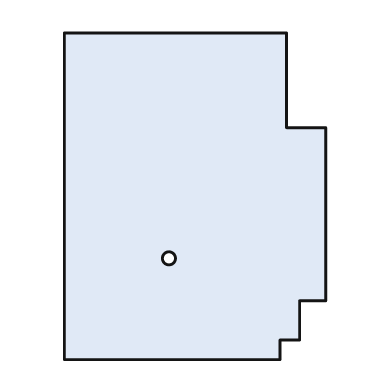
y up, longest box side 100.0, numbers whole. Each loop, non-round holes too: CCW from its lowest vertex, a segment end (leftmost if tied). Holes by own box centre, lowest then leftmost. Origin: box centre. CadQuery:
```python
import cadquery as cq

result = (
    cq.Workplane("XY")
    .moveTo(-40.0, -50.0)
    .lineTo(26.0, -50.0)
    .lineTo(26.0, -44.0)
    .lineTo(32.0, -44.0)
    .lineTo(32.0, -32.0)
    .lineTo(40.0, -32.0)
    .lineTo(40.0, 21.0)
    .lineTo(28.0, 21.0)
    .lineTo(28.0, 50.0)
    .lineTo(-40.0, 50.0)
    .close()
    .moveTo(-8.0, -19.0)
    .circle(2.0)
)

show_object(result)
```